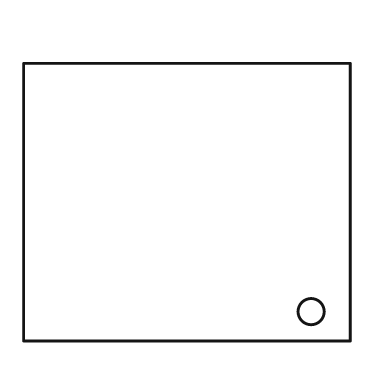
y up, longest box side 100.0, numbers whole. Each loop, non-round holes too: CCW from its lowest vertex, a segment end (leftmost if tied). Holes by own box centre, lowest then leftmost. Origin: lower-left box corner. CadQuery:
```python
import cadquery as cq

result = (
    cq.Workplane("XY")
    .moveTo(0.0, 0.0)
    .lineTo(100.0, 0.0)
    .lineTo(100.0, 85.0)
    .lineTo(0.0, 85.0)
    .close()
    .moveTo(88.0, 9.0)
    .circle(4.0)
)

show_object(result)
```